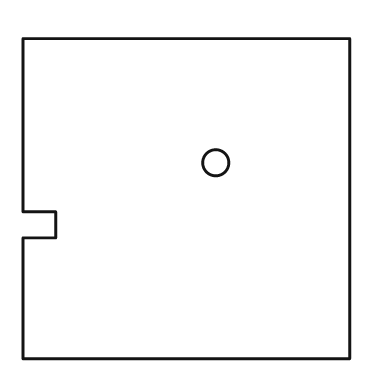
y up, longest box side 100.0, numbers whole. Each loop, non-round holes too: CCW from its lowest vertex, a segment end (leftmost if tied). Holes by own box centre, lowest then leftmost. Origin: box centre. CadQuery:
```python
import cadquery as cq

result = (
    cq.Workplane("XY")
    .moveTo(-50.0, -49.0)
    .lineTo(50.0, -49.0)
    .lineTo(50.0, 49.0)
    .lineTo(-50.0, 49.0)
    .lineTo(-50.0, -4.0)
    .lineTo(-40.0, -4.0)
    .lineTo(-40.0, -12.0)
    .lineTo(-50.0, -12.0)
    .close()
    .moveTo(9.0, 11.0)
    .circle(4.0)
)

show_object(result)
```